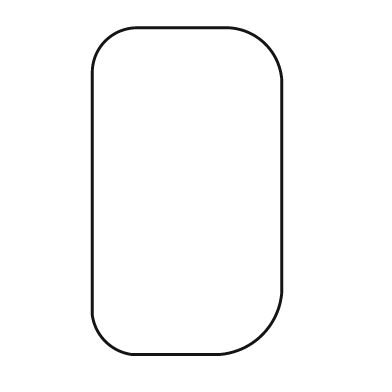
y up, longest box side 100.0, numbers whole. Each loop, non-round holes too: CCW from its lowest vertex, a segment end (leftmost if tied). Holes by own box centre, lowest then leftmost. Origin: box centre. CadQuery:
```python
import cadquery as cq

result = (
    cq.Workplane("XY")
    .moveTo(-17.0, -50.0)
    .lineTo(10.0, -50.0)
    .threePointArc((23.0, -44.0), (29.0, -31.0))
    .lineTo(29.0, 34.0)
    .threePointArc((24.0, 45.0), (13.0, 50.0))
    .lineTo(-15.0, 50.0)
    .threePointArc((-25.0, 46.0), (-29.0, 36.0))
    .lineTo(-29.0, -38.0)
    .threePointArc((-25.0, -46.0), (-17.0, -50.0))
    .close()
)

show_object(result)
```